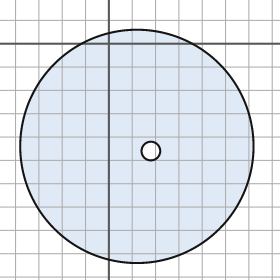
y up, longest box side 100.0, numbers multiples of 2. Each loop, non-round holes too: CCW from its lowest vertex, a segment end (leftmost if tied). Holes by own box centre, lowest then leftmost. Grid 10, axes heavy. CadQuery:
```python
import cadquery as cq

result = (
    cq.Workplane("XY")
    .moveTo(12.0, -44.0)
    .circle(50.0)
    .moveTo(18.0, -46.0)
    .circle(4.0)
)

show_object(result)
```